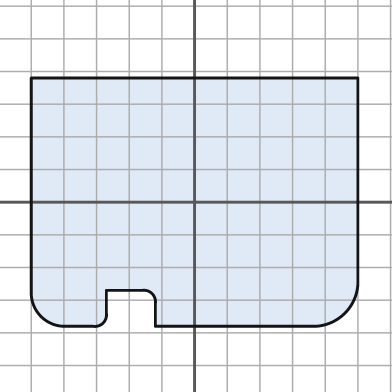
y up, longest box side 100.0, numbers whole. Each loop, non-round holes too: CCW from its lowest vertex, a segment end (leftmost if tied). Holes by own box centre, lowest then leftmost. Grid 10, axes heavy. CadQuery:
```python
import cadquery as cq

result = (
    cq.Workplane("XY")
    .moveTo(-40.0, -38.0)
    .lineTo(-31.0, -38.0)
    .threePointArc((-28.0, -37.0), (-27.0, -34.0))
    .lineTo(-27.0, -27.0)
    .lineTo(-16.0, -27.0)
    .threePointArc((-13.0, -28.0), (-12.0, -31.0))
    .lineTo(-12.0, -38.0)
    .lineTo(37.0, -38.0)
    .threePointArc((46.0, -34.0), (50.0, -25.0))
    .lineTo(50.0, 38.0)
    .lineTo(-50.0, 38.0)
    .lineTo(-50.0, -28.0)
    .threePointArc((-47.0, -35.0), (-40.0, -38.0))
    .close()
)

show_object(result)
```